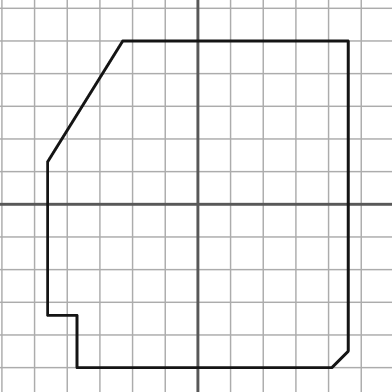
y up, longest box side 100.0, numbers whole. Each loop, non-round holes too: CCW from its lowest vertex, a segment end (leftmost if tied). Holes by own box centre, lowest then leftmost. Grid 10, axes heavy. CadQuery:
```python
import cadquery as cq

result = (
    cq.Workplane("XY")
    .moveTo(-37.0, -50.0)
    .lineTo(41.0, -50.0)
    .lineTo(46.0, -45.0)
    .lineTo(46.0, 50.0)
    .lineTo(-23.0, 50.0)
    .lineTo(-46.0, 13.0)
    .lineTo(-46.0, -34.0)
    .lineTo(-37.0, -34.0)
    .close()
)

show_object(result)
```